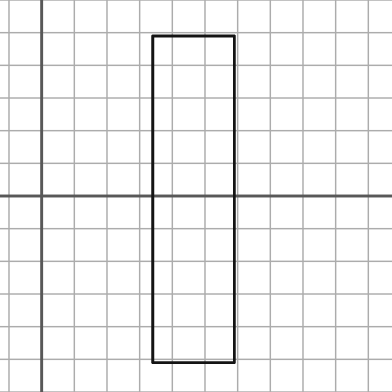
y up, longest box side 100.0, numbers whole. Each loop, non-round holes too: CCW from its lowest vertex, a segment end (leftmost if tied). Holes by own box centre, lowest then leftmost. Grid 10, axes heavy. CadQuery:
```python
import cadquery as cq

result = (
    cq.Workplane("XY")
    .moveTo(34.0, -51.0)
    .lineTo(59.0, -51.0)
    .lineTo(59.0, 49.0)
    .lineTo(34.0, 49.0)
    .close()
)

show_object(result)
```